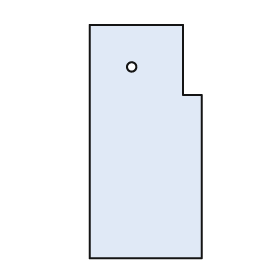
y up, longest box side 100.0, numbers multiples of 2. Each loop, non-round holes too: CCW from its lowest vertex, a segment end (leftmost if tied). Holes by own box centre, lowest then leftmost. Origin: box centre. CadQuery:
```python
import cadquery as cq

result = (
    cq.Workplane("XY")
    .moveTo(-24.0, -50.0)
    .lineTo(24.0, -50.0)
    .lineTo(24.0, 20.0)
    .lineTo(16.0, 20.0)
    .lineTo(16.0, 50.0)
    .lineTo(-24.0, 50.0)
    .close()
    .moveTo(-6.0, 32.0)
    .circle(2.0)
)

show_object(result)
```